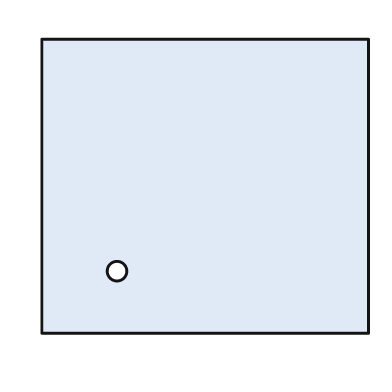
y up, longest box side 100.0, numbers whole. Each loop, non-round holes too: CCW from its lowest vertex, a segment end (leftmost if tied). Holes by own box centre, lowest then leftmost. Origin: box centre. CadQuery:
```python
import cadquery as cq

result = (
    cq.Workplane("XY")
    .moveTo(-50.0, -45.0)
    .lineTo(50.0, -45.0)
    .lineTo(50.0, 45.0)
    .lineTo(-50.0, 45.0)
    .close()
    .moveTo(-27.0, -26.0)
    .circle(3.0)
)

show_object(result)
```